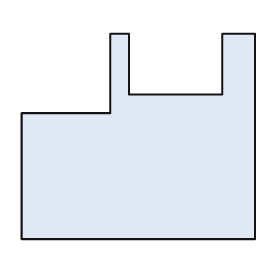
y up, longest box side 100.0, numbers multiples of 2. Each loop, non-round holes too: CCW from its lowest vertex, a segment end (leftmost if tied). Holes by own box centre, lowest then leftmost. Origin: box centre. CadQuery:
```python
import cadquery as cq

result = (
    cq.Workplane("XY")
    .moveTo(-50.0, -44.0)
    .lineTo(50.0, -44.0)
    .lineTo(50.0, 44.0)
    .lineTo(36.0, 44.0)
    .lineTo(36.0, 18.0)
    .lineTo(-4.0, 18.0)
    .lineTo(-4.0, 44.0)
    .lineTo(-12.0, 44.0)
    .lineTo(-12.0, 10.0)
    .lineTo(-50.0, 10.0)
    .close()
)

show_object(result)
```